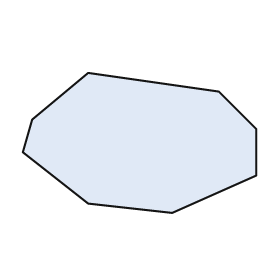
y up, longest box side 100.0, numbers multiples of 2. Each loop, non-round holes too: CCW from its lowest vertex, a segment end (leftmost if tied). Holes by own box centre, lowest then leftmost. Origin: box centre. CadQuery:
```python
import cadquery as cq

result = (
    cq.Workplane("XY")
    .moveTo(14.0, -30.0)
    .lineTo(50.0, -14.0)
    .lineTo(50.0, 6.0)
    .lineTo(34.0, 22.0)
    .lineTo(-22.0, 30.0)
    .lineTo(-46.0, 10.0)
    .lineTo(-50.0, -4.0)
    .lineTo(-22.0, -26.0)
    .close()
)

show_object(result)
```